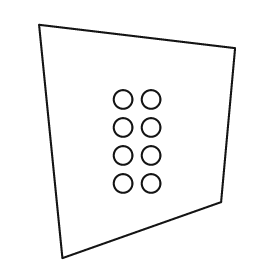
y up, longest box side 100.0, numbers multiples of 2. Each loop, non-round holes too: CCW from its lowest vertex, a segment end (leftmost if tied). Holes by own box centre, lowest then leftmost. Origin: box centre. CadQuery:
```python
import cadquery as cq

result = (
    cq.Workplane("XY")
    .moveTo(-32.0, -50.0)
    .lineTo(36.0, -26.0)
    .lineTo(42.0, 40.0)
    .lineTo(-42.0, 50.0)
    .close()
    .moveTo(-6.0, -18.0)
    .circle(4.0)
    .moveTo(6.0, -18.0)
    .circle(4.0)
    .moveTo(-6.0, -6.0)
    .circle(4.0)
    .moveTo(6.0, -6.0)
    .circle(4.0)
    .moveTo(-6.0, 6.0)
    .circle(4.0)
    .moveTo(6.0, 6.0)
    .circle(4.0)
    .moveTo(-6.0, 18.0)
    .circle(4.0)
    .moveTo(6.0, 18.0)
    .circle(4.0)
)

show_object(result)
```